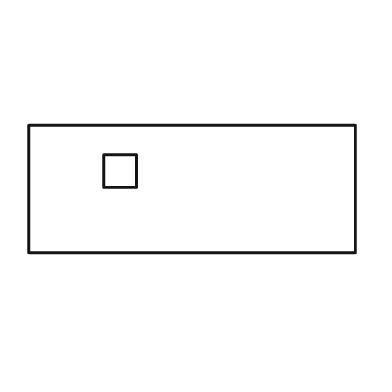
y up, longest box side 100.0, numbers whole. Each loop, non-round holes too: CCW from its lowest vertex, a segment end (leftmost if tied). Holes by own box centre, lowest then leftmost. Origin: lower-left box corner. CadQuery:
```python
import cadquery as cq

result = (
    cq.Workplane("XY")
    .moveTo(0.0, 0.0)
    .lineTo(100.0, 0.0)
    .lineTo(100.0, 39.0)
    .lineTo(0.0, 39.0)
    .close()
    .moveTo(23.0, 20.0)
    .lineTo(33.0, 20.0)
    .lineTo(33.0, 30.0)
    .lineTo(23.0, 30.0)
    .close()
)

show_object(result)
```